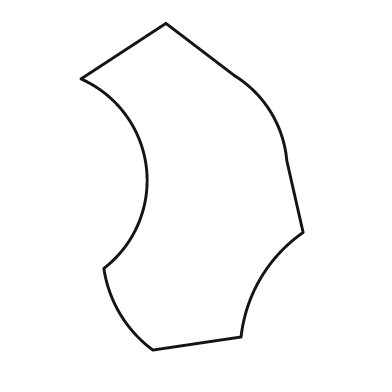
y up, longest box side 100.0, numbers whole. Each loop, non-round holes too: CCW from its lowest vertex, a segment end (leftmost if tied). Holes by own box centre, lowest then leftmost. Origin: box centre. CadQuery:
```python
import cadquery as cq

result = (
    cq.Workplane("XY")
    .moveTo(-12.0, -50.0)
    .lineTo(15.0, -46.0)
    .threePointArc((21.0, -28.0), (34.0, -14.0))
    .lineTo(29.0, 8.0)
    .threePointArc((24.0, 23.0), (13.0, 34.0))
    .lineTo(-8.0, 50.0)
    .lineTo(-34.0, 33.0)
    .threePointArc((-14.0, 6.0), (-27.0, -25.0))
    .threePointArc((-22.0, -39.0), (-12.0, -50.0))
    .close()
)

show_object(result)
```